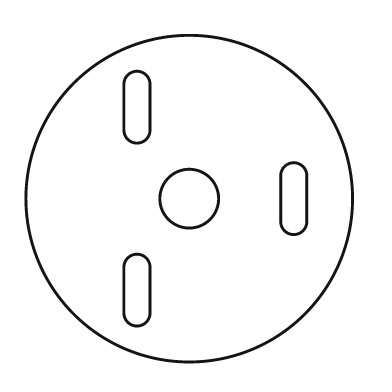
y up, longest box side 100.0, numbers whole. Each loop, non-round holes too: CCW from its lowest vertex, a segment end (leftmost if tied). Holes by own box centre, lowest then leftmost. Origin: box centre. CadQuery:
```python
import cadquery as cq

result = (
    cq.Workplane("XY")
    .moveTo(0.0, 0.0)
    .circle(50.0)
    .moveTo(-20.0, -35.0)
    .threePointArc((-16.0, -39.0), (-12.0, -35.0))
    .lineTo(-12.0, -21.0)
    .threePointArc((-16.0, -17.0), (-20.0, -21.0))
    .close()
    .moveTo(0.0, 0.0)
    .circle(9.0)
    .moveTo(28.0, -7.0)
    .threePointArc((32.0, -11.0), (36.0, -7.0))
    .lineTo(36.0, 7.0)
    .threePointArc((32.0, 11.0), (28.0, 7.0))
    .close()
    .moveTo(-20.0, 21.0)
    .threePointArc((-16.0, 17.0), (-12.0, 21.0))
    .lineTo(-12.0, 35.0)
    .threePointArc((-16.0, 39.0), (-20.0, 35.0))
    .close()
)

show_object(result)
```